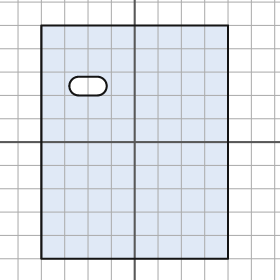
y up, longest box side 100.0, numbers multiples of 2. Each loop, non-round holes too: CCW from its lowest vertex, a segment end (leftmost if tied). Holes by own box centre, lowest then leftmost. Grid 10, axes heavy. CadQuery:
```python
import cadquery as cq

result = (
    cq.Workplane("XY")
    .moveTo(-40.0, -50.0)
    .lineTo(40.0, -50.0)
    .lineTo(40.0, 50.0)
    .lineTo(-40.0, 50.0)
    .close()
    .moveTo(-24.0, 20.0)
    .lineTo(-16.0, 20.0)
    .threePointArc((-12.0, 24.0), (-16.0, 28.0))
    .lineTo(-24.0, 28.0)
    .threePointArc((-28.0, 24.0), (-24.0, 20.0))
    .close()
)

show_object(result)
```